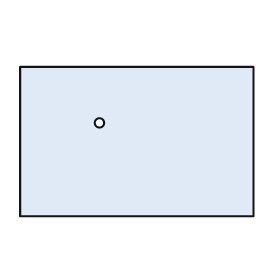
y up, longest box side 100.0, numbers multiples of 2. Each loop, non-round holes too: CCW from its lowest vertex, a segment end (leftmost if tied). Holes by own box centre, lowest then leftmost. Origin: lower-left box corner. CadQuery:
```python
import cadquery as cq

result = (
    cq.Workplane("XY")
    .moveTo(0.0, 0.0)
    .lineTo(100.0, 0.0)
    .lineTo(100.0, 64.0)
    .lineTo(0.0, 64.0)
    .close()
    .moveTo(34.0, 40.0)
    .circle(2.0)
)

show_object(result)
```